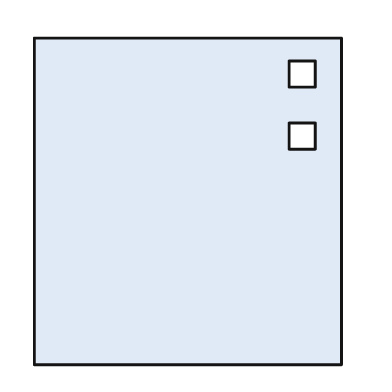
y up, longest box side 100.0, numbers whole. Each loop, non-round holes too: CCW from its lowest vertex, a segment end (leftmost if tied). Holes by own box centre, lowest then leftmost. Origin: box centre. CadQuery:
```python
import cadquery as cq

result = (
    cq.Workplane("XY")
    .moveTo(-47.0, -50.0)
    .lineTo(47.0, -50.0)
    .lineTo(47.0, 50.0)
    .lineTo(-47.0, 50.0)
    .close()
    .moveTo(31.0, 16.0)
    .lineTo(39.0, 16.0)
    .lineTo(39.0, 24.0)
    .lineTo(31.0, 24.0)
    .close()
    .moveTo(31.0, 35.0)
    .lineTo(39.0, 35.0)
    .lineTo(39.0, 43.0)
    .lineTo(31.0, 43.0)
    .close()
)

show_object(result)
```